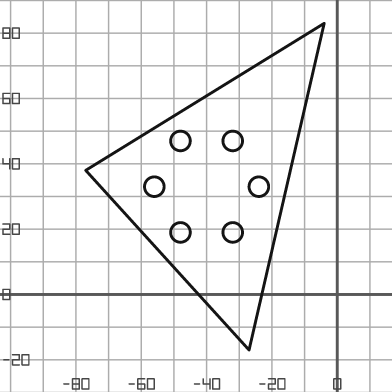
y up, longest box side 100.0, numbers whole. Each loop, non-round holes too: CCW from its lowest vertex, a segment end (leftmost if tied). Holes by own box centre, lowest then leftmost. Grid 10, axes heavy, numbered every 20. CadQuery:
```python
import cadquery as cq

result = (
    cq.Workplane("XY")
    .moveTo(-27.0, -17.0)
    .lineTo(-4.0, 83.0)
    .lineTo(-77.0, 38.0)
    .close()
    .moveTo(-48.0, 19.0)
    .circle(3.0)
    .moveTo(-32.0, 19.0)
    .circle(3.0)
    .moveTo(-56.0, 33.0)
    .circle(3.0)
    .moveTo(-24.0, 33.0)
    .circle(3.0)
    .moveTo(-48.0, 47.0)
    .circle(3.0)
    .moveTo(-32.0, 47.0)
    .circle(3.0)
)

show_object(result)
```